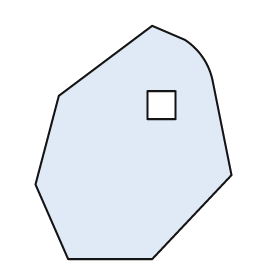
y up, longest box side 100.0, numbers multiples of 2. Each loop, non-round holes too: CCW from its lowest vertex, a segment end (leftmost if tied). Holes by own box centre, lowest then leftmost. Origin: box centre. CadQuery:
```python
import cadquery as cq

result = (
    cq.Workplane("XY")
    .moveTo(-28.0, -50.0)
    .lineTo(8.0, -50.0)
    .lineTo(42.0, -14.0)
    .lineTo(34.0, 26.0)
    .threePointArc((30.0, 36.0), (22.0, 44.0))
    .lineTo(8.0, 50.0)
    .lineTo(-32.0, 20.0)
    .lineTo(-42.0, -18.0)
    .close()
    .moveTo(6.0, 10.0)
    .lineTo(18.0, 10.0)
    .lineTo(18.0, 22.0)
    .lineTo(6.0, 22.0)
    .close()
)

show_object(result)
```